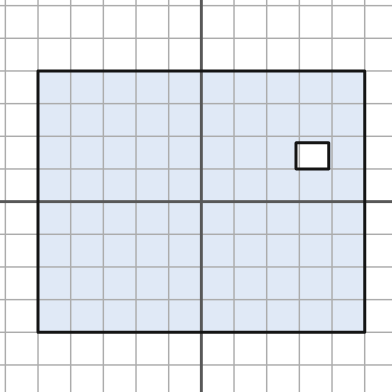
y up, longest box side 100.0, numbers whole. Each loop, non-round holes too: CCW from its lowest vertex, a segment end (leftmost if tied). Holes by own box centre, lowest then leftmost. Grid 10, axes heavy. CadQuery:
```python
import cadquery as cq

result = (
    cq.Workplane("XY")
    .moveTo(-50.0, -40.0)
    .lineTo(50.0, -40.0)
    .lineTo(50.0, 40.0)
    .lineTo(-50.0, 40.0)
    .close()
    .moveTo(29.0, 10.0)
    .lineTo(39.0, 10.0)
    .lineTo(39.0, 18.0)
    .lineTo(29.0, 18.0)
    .close()
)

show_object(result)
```